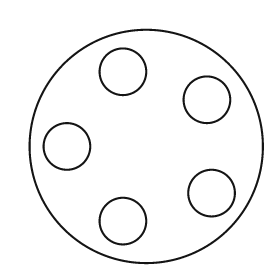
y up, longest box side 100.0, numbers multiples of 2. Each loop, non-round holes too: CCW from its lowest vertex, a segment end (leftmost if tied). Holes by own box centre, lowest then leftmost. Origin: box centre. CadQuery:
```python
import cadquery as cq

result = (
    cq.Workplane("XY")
    .moveTo(0.0, 0.0)
    .circle(50.0)
    .moveTo(-10.0, -32.0)
    .circle(10.0)
    .moveTo(28.0, -20.0)
    .circle(10.0)
    .moveTo(-34.0, 0.0)
    .circle(10.0)
    .moveTo(26.0, 20.0)
    .circle(10.0)
    .moveTo(-10.0, 32.0)
    .circle(10.0)
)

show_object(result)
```